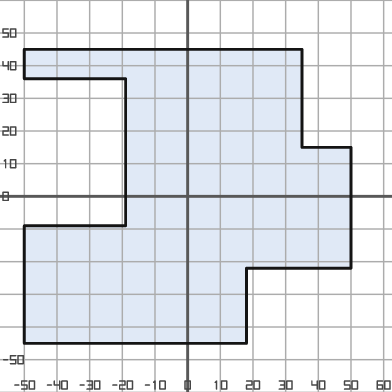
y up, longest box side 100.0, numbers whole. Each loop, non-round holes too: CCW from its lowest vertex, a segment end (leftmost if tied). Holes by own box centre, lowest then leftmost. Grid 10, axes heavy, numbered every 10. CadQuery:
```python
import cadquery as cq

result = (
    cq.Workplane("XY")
    .moveTo(-50.0, -45.0)
    .lineTo(18.0, -45.0)
    .lineTo(18.0, -22.0)
    .lineTo(50.0, -22.0)
    .lineTo(50.0, 15.0)
    .lineTo(35.0, 15.0)
    .lineTo(35.0, 45.0)
    .lineTo(-50.0, 45.0)
    .lineTo(-50.0, 36.0)
    .lineTo(-19.0, 36.0)
    .lineTo(-19.0, -9.0)
    .lineTo(-50.0, -9.0)
    .close()
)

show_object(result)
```